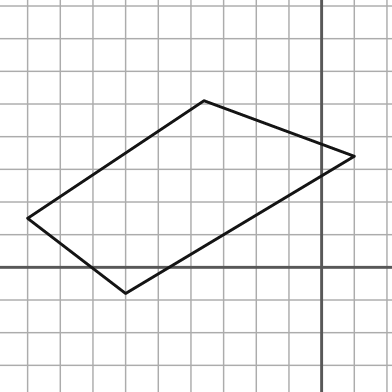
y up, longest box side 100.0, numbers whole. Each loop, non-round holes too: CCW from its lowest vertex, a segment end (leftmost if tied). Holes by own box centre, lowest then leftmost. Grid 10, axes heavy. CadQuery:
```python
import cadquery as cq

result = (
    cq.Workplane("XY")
    .moveTo(-60.0, -8.0)
    .lineTo(10.0, 34.0)
    .lineTo(-36.0, 51.0)
    .lineTo(-90.0, 15.0)
    .close()
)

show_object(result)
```